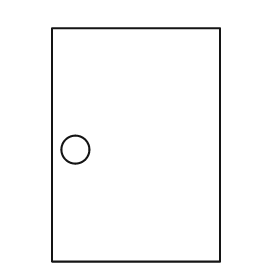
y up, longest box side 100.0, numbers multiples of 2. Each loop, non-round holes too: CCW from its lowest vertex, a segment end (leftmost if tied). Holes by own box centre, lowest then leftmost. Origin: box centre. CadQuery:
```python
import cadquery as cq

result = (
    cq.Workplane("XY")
    .moveTo(-36.0, -50.0)
    .lineTo(36.0, -50.0)
    .lineTo(36.0, 50.0)
    .lineTo(-36.0, 50.0)
    .close()
    .moveTo(-26.0, -2.0)
    .circle(6.0)
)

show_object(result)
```